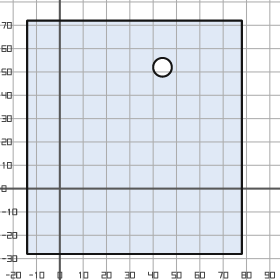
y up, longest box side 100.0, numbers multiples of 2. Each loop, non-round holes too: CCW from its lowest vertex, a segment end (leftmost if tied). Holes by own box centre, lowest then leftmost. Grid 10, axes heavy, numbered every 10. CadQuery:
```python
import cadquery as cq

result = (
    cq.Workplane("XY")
    .moveTo(-14.0, -28.0)
    .lineTo(78.0, -28.0)
    .lineTo(78.0, 72.0)
    .lineTo(-14.0, 72.0)
    .close()
    .moveTo(44.0, 52.0)
    .circle(4.0)
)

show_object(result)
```